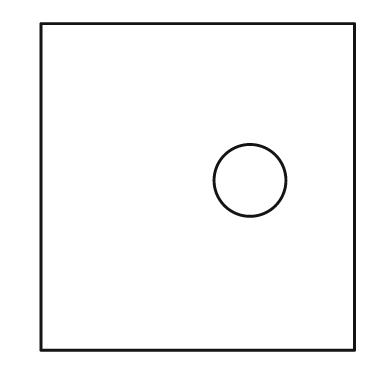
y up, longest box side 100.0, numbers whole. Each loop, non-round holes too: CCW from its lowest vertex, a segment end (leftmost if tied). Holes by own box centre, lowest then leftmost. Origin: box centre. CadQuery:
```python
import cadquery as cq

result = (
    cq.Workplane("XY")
    .moveTo(-48.0, -50.0)
    .lineTo(48.0, -50.0)
    .lineTo(48.0, 50.0)
    .lineTo(-48.0, 50.0)
    .close()
    .moveTo(16.0, 2.0)
    .circle(11.0)
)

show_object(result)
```